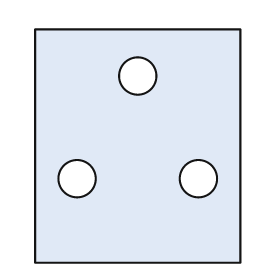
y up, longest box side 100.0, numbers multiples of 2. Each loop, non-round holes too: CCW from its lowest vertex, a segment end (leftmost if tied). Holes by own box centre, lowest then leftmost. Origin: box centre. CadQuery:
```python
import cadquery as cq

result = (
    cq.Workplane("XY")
    .moveTo(-44.0, -50.0)
    .lineTo(44.0, -50.0)
    .lineTo(44.0, 50.0)
    .lineTo(-44.0, 50.0)
    .close()
    .moveTo(-26.0, -14.0)
    .circle(8.0)
    .moveTo(26.0, -14.0)
    .circle(8.0)
    .moveTo(0.0, 30.0)
    .circle(8.0)
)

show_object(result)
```